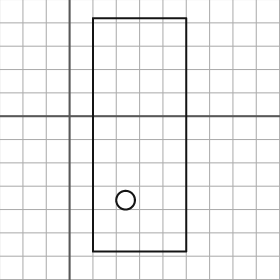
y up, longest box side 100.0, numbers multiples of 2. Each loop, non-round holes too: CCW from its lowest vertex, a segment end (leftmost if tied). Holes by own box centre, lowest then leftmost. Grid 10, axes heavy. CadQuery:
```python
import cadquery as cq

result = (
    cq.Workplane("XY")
    .moveTo(10.0, -58.0)
    .lineTo(50.0, -58.0)
    .lineTo(50.0, 42.0)
    .lineTo(10.0, 42.0)
    .close()
    .moveTo(24.0, -36.0)
    .circle(4.0)
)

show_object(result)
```